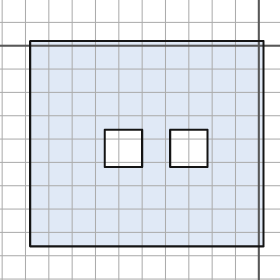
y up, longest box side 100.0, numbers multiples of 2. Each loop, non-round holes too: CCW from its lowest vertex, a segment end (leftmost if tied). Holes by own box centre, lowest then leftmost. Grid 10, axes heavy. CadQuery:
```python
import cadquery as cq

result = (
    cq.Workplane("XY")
    .moveTo(-98.0, -86.0)
    .lineTo(2.0, -86.0)
    .lineTo(2.0, 2.0)
    .lineTo(-98.0, 2.0)
    .close()
    .moveTo(-66.0, -52.0)
    .lineTo(-50.0, -52.0)
    .lineTo(-50.0, -36.0)
    .lineTo(-66.0, -36.0)
    .close()
    .moveTo(-38.0, -52.0)
    .lineTo(-22.0, -52.0)
    .lineTo(-22.0, -36.0)
    .lineTo(-38.0, -36.0)
    .close()
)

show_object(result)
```